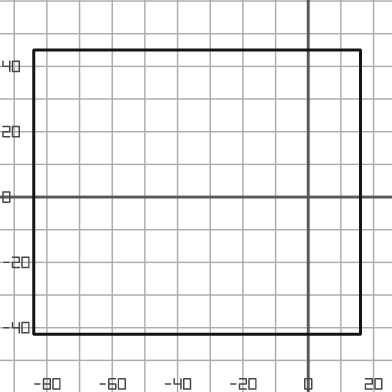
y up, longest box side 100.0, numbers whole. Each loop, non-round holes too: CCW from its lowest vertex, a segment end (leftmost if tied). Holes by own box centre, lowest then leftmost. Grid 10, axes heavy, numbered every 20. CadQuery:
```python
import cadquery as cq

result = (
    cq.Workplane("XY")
    .moveTo(-84.0, -42.0)
    .lineTo(16.0, -42.0)
    .lineTo(16.0, 45.0)
    .lineTo(-84.0, 45.0)
    .close()
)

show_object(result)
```